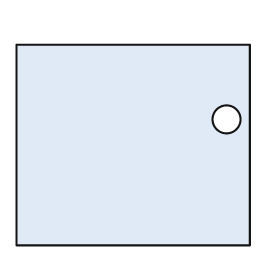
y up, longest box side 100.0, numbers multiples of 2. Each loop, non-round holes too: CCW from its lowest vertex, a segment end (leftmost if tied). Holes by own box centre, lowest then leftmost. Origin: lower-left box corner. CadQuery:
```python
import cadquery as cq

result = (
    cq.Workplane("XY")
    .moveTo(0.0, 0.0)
    .lineTo(100.0, 0.0)
    .lineTo(100.0, 86.0)
    .lineTo(0.0, 86.0)
    .close()
    .moveTo(90.0, 54.0)
    .circle(6.0)
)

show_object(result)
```